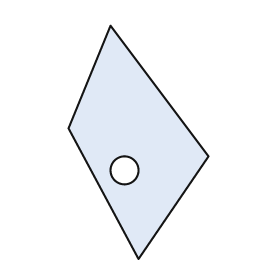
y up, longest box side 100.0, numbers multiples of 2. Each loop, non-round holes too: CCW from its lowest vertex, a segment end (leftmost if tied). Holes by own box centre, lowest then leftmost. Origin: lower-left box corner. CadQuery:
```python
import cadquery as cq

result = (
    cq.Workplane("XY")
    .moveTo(30.0, 0.0)
    .lineTo(60.0, 44.0)
    .lineTo(18.0, 100.0)
    .lineTo(0.0, 56.0)
    .close()
    .moveTo(24.0, 38.0)
    .circle(6.0)
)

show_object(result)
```